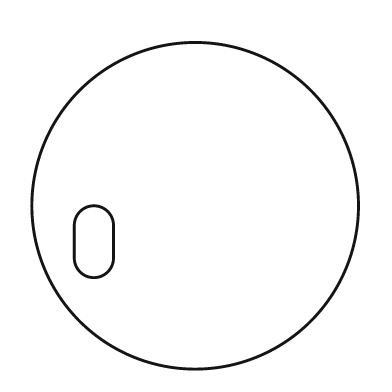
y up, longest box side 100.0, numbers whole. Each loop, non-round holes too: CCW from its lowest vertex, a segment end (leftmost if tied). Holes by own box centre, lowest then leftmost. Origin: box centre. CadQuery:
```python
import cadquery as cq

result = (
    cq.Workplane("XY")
    .moveTo(0.0, 0.0)
    .circle(50.0)
    .moveTo(-37.0, -16.0)
    .threePointArc((-31.0, -22.0), (-25.0, -16.0))
    .lineTo(-25.0, -6.0)
    .threePointArc((-31.0, 0.0), (-37.0, -6.0))
    .close()
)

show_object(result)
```